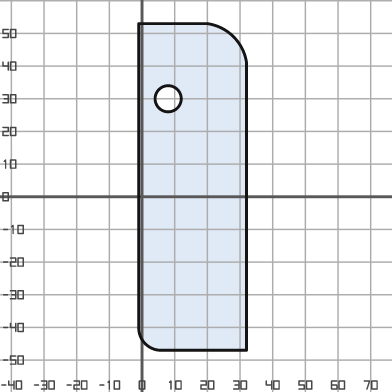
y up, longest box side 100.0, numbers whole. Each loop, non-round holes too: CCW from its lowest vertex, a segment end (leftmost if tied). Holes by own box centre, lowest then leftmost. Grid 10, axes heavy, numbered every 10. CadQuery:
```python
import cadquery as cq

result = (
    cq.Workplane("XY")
    .moveTo(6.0, -47.0)
    .lineTo(32.0, -47.0)
    .lineTo(32.0, 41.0)
    .threePointArc((28.0, 49.0), (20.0, 53.0))
    .lineTo(-1.0, 53.0)
    .lineTo(-1.0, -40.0)
    .threePointArc((1.0, -45.0), (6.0, -47.0))
    .close()
    .moveTo(8.0, 30.0)
    .circle(4.0)
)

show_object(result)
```